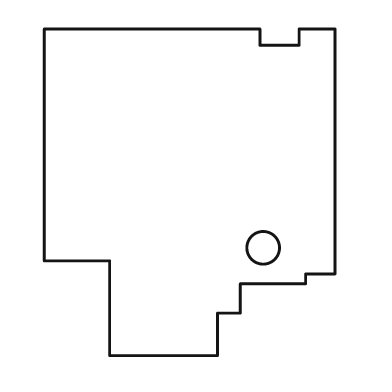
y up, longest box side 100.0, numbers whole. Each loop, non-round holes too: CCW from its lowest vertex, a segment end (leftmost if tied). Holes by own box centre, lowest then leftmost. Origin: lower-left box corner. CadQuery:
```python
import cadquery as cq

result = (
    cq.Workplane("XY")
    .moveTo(20.0, 0.0)
    .lineTo(53.0, 0.0)
    .lineTo(53.0, 13.0)
    .lineTo(60.0, 13.0)
    .lineTo(60.0, 22.0)
    .lineTo(80.0, 22.0)
    .lineTo(80.0, 25.0)
    .lineTo(89.0, 25.0)
    .lineTo(89.0, 100.0)
    .lineTo(78.0, 100.0)
    .lineTo(78.0, 95.0)
    .lineTo(66.0, 95.0)
    .lineTo(66.0, 100.0)
    .lineTo(0.0, 100.0)
    .lineTo(0.0, 29.0)
    .lineTo(20.0, 29.0)
    .close()
    .moveTo(67.0, 33.0)
    .circle(5.0)
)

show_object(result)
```